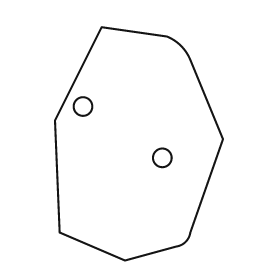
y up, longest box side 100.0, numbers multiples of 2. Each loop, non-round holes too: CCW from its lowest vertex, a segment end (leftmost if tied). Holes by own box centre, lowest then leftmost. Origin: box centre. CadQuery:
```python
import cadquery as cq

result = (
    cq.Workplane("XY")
    .moveTo(-6.0, -50.0)
    .lineTo(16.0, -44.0)
    .threePointArc((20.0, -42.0), (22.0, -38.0))
    .lineTo(36.0, 2.0)
    .lineTo(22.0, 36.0)
    .threePointArc((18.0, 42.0), (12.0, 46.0))
    .lineTo(-16.0, 50.0)
    .lineTo(-36.0, 10.0)
    .lineTo(-34.0, -38.0)
    .close()
    .moveTo(10.0, -6.0)
    .circle(4.0)
    .moveTo(-24.0, 16.0)
    .circle(4.0)
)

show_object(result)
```